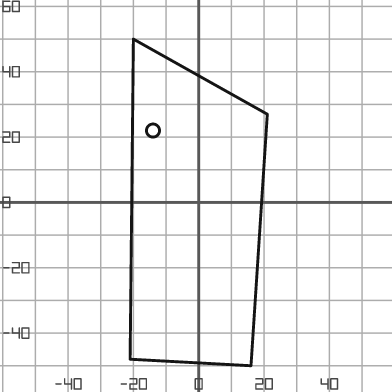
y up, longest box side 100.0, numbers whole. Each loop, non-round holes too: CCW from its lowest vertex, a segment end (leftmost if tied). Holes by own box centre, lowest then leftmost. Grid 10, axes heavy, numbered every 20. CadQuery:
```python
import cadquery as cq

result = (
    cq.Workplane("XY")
    .moveTo(16.0, -50.0)
    .lineTo(21.0, 27.0)
    .lineTo(-20.0, 50.0)
    .lineTo(-21.0, -48.0)
    .close()
    .moveTo(-14.0, 22.0)
    .circle(2.0)
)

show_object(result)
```